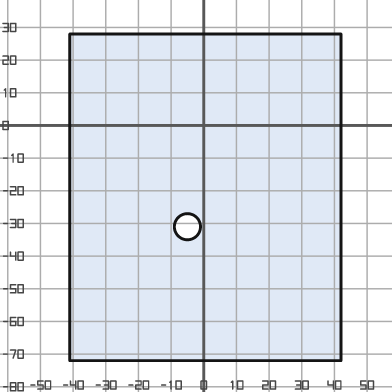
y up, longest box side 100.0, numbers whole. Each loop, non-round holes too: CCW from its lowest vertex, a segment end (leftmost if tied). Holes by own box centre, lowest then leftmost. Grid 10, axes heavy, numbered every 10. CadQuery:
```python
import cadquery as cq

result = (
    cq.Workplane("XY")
    .moveTo(-41.0, -72.0)
    .lineTo(42.0, -72.0)
    .lineTo(42.0, 28.0)
    .lineTo(-41.0, 28.0)
    .close()
    .moveTo(-5.0, -31.0)
    .circle(4.0)
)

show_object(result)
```